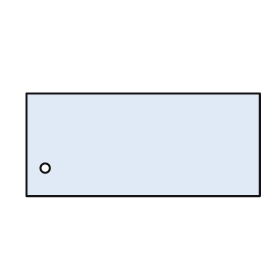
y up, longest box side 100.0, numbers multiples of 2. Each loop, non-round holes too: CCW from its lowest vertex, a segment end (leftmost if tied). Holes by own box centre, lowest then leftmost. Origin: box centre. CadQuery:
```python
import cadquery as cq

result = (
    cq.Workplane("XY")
    .moveTo(-50.0, -22.0)
    .lineTo(50.0, -22.0)
    .lineTo(50.0, 22.0)
    .lineTo(-50.0, 22.0)
    .close()
    .moveTo(-42.0, -10.0)
    .circle(2.0)
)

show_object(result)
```